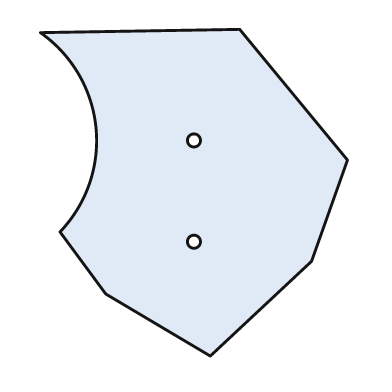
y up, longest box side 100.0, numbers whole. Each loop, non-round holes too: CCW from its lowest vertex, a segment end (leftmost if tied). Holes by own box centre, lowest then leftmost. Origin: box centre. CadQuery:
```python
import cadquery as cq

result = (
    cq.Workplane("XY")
    .moveTo(5.0, -50.0)
    .lineTo(36.0, -21.0)
    .lineTo(47.0, 10.0)
    .lineTo(14.0, 50.0)
    .lineTo(-47.0, 49.0)
    .threePointArc((-30.0, 20.0), (-41.0, -12.0))
    .lineTo(-27.0, -31.0)
    .close()
    .moveTo(0.0, -15.0)
    .circle(2.0)
    .moveTo(0.0, 16.0)
    .circle(2.0)
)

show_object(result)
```